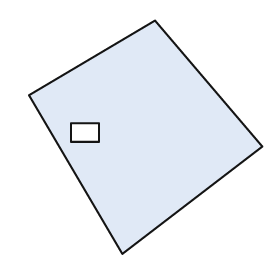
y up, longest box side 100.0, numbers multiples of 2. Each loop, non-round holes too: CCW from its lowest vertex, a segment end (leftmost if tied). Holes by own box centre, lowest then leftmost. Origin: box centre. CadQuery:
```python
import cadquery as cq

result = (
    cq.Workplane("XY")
    .moveTo(-10.0, -50.0)
    .lineTo(50.0, -4.0)
    .lineTo(4.0, 50.0)
    .lineTo(-50.0, 18.0)
    .close()
    .moveTo(-32.0, -2.0)
    .lineTo(-20.0, -2.0)
    .lineTo(-20.0, 6.0)
    .lineTo(-32.0, 6.0)
    .close()
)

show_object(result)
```